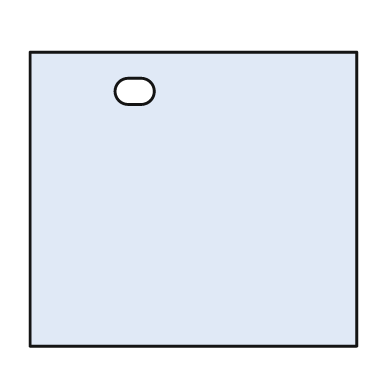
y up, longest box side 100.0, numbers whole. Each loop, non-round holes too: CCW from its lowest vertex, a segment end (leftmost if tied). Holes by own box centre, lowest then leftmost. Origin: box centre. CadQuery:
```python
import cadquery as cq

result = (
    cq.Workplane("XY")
    .moveTo(-50.0, -45.0)
    .lineTo(50.0, -45.0)
    .lineTo(50.0, 45.0)
    .lineTo(-50.0, 45.0)
    .close()
    .moveTo(-20.0, 29.0)
    .lineTo(-16.0, 29.0)
    .threePointArc((-12.0, 33.0), (-16.0, 37.0))
    .lineTo(-20.0, 37.0)
    .threePointArc((-24.0, 33.0), (-20.0, 29.0))
    .close()
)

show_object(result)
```